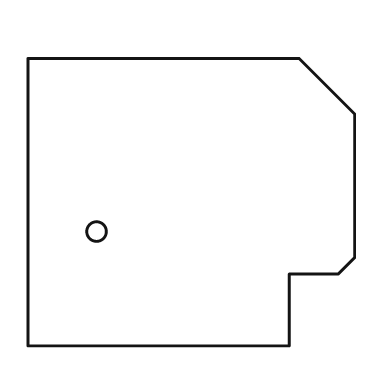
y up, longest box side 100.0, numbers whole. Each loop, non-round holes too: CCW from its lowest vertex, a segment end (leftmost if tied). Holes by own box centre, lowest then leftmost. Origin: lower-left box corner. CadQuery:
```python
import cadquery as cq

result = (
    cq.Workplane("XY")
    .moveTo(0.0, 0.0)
    .lineTo(80.0, 0.0)
    .lineTo(80.0, 22.0)
    .lineTo(95.0, 22.0)
    .lineTo(100.0, 27.0)
    .lineTo(100.0, 71.0)
    .lineTo(83.0, 88.0)
    .lineTo(0.0, 88.0)
    .close()
    .moveTo(21.0, 35.0)
    .circle(3.0)
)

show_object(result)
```